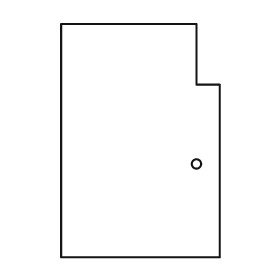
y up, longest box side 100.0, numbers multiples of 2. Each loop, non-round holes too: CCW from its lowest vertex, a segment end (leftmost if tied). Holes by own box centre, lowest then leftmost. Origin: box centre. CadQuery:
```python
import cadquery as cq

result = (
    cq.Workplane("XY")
    .moveTo(-34.0, -50.0)
    .lineTo(34.0, -50.0)
    .lineTo(34.0, 24.0)
    .lineTo(24.0, 24.0)
    .lineTo(24.0, 50.0)
    .lineTo(-34.0, 50.0)
    .close()
    .moveTo(24.0, -10.0)
    .circle(2.0)
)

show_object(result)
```